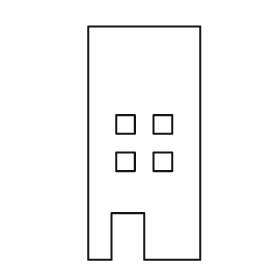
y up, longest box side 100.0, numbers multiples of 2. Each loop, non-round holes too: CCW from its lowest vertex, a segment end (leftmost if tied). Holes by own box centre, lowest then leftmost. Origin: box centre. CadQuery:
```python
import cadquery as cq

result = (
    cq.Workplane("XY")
    .moveTo(-24.0, -50.0)
    .lineTo(-14.0, -50.0)
    .lineTo(-14.0, -30.0)
    .lineTo(0.0, -30.0)
    .lineTo(0.0, -50.0)
    .lineTo(24.0, -50.0)
    .lineTo(24.0, 50.0)
    .lineTo(-24.0, 50.0)
    .close()
    .moveTo(-12.0, -12.0)
    .lineTo(-4.0, -12.0)
    .lineTo(-4.0, -4.0)
    .lineTo(-12.0, -4.0)
    .close()
    .moveTo(4.0, -12.0)
    .lineTo(12.0, -12.0)
    .lineTo(12.0, -4.0)
    .lineTo(4.0, -4.0)
    .close()
    .moveTo(-12.0, 4.0)
    .lineTo(-4.0, 4.0)
    .lineTo(-4.0, 12.0)
    .lineTo(-12.0, 12.0)
    .close()
    .moveTo(4.0, 4.0)
    .lineTo(12.0, 4.0)
    .lineTo(12.0, 12.0)
    .lineTo(4.0, 12.0)
    .close()
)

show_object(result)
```